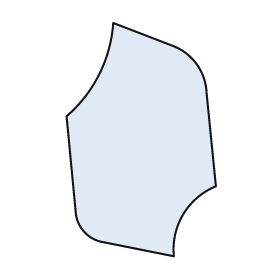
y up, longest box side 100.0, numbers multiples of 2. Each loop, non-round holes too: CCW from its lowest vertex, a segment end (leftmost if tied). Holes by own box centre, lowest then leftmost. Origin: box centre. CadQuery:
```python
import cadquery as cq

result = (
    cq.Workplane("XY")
    .moveTo(14.0, -50.0)
    .threePointArc((18.0, -32.0), (32.0, -20.0))
    .lineTo(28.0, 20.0)
    .threePointArc((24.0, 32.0), (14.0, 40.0))
    .lineTo(-12.0, 50.0)
    .threePointArc((-18.0, 28.0), (-32.0, 10.0))
    .lineTo(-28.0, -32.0)
    .threePointArc((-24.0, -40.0), (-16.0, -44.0))
    .close()
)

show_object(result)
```